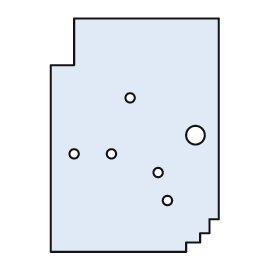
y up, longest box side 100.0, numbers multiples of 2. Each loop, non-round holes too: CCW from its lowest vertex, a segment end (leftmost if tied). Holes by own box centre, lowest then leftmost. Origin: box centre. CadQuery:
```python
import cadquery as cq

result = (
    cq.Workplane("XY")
    .moveTo(-36.0, -50.0)
    .lineTo(22.0, -50.0)
    .lineTo(22.0, -46.0)
    .lineTo(28.0, -46.0)
    .lineTo(28.0, -42.0)
    .lineTo(32.0, -42.0)
    .lineTo(32.0, -36.0)
    .lineTo(36.0, -36.0)
    .lineTo(36.0, 50.0)
    .lineTo(-26.0, 50.0)
    .lineTo(-26.0, 30.0)
    .lineTo(-36.0, 30.0)
    .close()
    .moveTo(14.0, -28.0)
    .circle(2.0)
    .moveTo(10.0, -16.0)
    .circle(2.0)
    .moveTo(-26.0, -8.0)
    .circle(2.0)
    .moveTo(-10.0, -8.0)
    .circle(2.0)
    .moveTo(26.0, 0.0)
    .circle(4.0)
    .moveTo(-2.0, 16.0)
    .circle(2.0)
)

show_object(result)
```